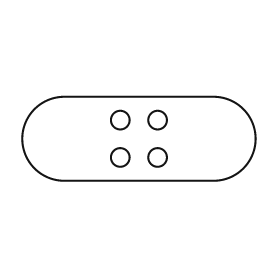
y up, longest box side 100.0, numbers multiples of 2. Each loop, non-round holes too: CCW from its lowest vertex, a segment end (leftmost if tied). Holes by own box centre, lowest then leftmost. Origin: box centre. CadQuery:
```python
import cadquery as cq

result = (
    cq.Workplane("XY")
    .moveTo(-32.0, -18.0)
    .lineTo(32.0, -18.0)
    .threePointArc((50.0, 0.0), (32.0, 18.0))
    .lineTo(-32.0, 18.0)
    .threePointArc((-50.0, 0.0), (-32.0, -18.0))
    .close()
    .moveTo(-8.0, -8.0)
    .circle(4.0)
    .moveTo(8.0, -8.0)
    .circle(4.0)
    .moveTo(-8.0, 8.0)
    .circle(4.0)
    .moveTo(8.0, 8.0)
    .circle(4.0)
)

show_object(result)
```